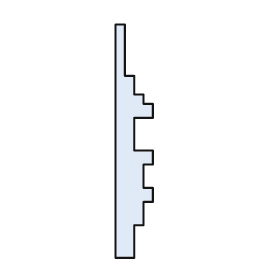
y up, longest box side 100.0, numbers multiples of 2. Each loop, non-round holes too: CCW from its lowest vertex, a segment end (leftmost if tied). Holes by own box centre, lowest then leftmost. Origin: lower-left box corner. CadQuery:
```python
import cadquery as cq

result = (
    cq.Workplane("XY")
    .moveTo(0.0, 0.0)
    .lineTo(8.0, 0.0)
    .lineTo(8.0, 14.0)
    .lineTo(12.0, 14.0)
    .lineTo(12.0, 24.0)
    .lineTo(16.0, 24.0)
    .lineTo(16.0, 30.0)
    .lineTo(12.0, 30.0)
    .lineTo(12.0, 40.0)
    .lineTo(16.0, 40.0)
    .lineTo(16.0, 46.0)
    .lineTo(8.0, 46.0)
    .lineTo(8.0, 60.0)
    .lineTo(16.0, 60.0)
    .lineTo(16.0, 66.0)
    .lineTo(12.0, 66.0)
    .lineTo(12.0, 70.0)
    .lineTo(8.0, 70.0)
    .lineTo(8.0, 78.0)
    .lineTo(4.0, 78.0)
    .lineTo(4.0, 100.0)
    .lineTo(0.0, 100.0)
    .close()
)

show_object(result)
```